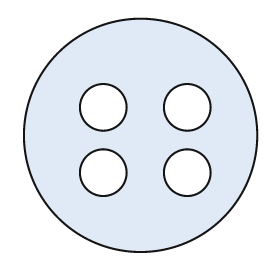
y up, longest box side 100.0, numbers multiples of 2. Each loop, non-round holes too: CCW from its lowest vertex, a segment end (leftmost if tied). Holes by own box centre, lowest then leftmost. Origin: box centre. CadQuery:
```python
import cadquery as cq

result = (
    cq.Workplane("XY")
    .moveTo(0.0, 0.0)
    .circle(50.0)
    .moveTo(-16.0, -16.0)
    .circle(10.0)
    .moveTo(20.0, -16.0)
    .circle(10.0)
    .moveTo(-16.0, 12.0)
    .circle(10.0)
    .moveTo(20.0, 12.0)
    .circle(10.0)
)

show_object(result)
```